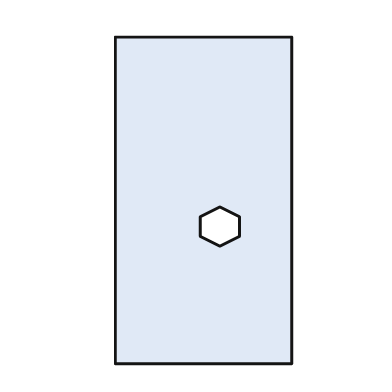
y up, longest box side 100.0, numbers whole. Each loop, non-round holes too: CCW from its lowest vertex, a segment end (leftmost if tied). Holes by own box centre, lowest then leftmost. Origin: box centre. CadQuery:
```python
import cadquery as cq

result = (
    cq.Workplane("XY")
    .moveTo(-27.0, -50.0)
    .lineTo(27.0, -50.0)
    .lineTo(27.0, 50.0)
    .lineTo(-27.0, 50.0)
    .close()
    .moveTo(5.0, -14.0)
    .lineTo(11.0, -11.0)
    .lineTo(11.0, -5.0)
    .lineTo(5.0, -2.0)
    .lineTo(-1.0, -5.0)
    .lineTo(-1.0, -11.0)
    .close()
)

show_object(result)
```